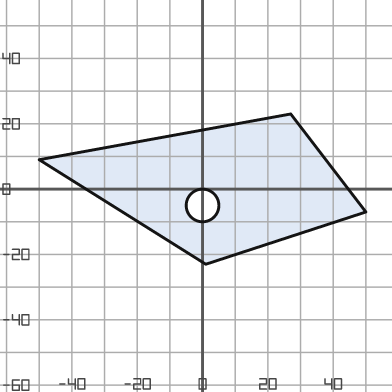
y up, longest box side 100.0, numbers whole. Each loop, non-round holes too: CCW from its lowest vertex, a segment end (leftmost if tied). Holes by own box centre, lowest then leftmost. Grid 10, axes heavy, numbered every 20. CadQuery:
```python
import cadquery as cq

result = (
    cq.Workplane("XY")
    .moveTo(1.0, -23.0)
    .lineTo(50.0, -7.0)
    .lineTo(27.0, 23.0)
    .lineTo(-50.0, 9.0)
    .close()
    .moveTo(0.0, -5.0)
    .circle(5.0)
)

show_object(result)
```